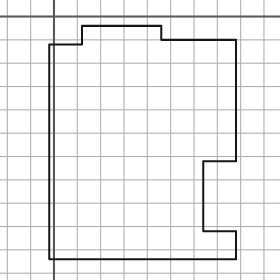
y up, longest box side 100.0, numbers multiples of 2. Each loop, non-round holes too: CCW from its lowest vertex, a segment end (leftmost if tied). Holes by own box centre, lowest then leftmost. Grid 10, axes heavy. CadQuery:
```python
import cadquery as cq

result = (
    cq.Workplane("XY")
    .moveTo(-2.0, -104.0)
    .lineTo(78.0, -104.0)
    .lineTo(78.0, -92.0)
    .lineTo(64.0, -92.0)
    .lineTo(64.0, -62.0)
    .lineTo(78.0, -62.0)
    .lineTo(78.0, -10.0)
    .lineTo(46.0, -10.0)
    .lineTo(46.0, -4.0)
    .lineTo(12.0, -4.0)
    .lineTo(12.0, -12.0)
    .lineTo(-2.0, -12.0)
    .close()
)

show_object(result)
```